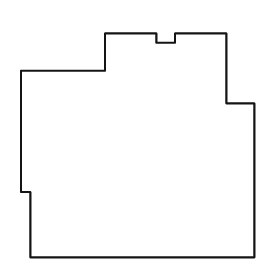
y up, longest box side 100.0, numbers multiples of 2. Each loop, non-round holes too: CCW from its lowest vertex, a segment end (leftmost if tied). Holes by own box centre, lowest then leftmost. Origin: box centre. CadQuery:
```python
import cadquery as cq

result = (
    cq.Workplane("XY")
    .moveTo(-46.0, -48.0)
    .lineTo(50.0, -48.0)
    .lineTo(50.0, 18.0)
    .lineTo(38.0, 18.0)
    .lineTo(38.0, 48.0)
    .lineTo(16.0, 48.0)
    .lineTo(16.0, 44.0)
    .lineTo(8.0, 44.0)
    .lineTo(8.0, 48.0)
    .lineTo(-14.0, 48.0)
    .lineTo(-14.0, 32.0)
    .lineTo(-50.0, 32.0)
    .lineTo(-50.0, -20.0)
    .lineTo(-46.0, -20.0)
    .close()
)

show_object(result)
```